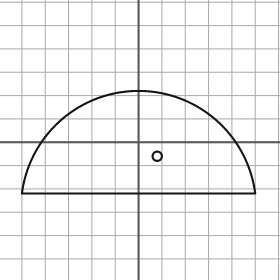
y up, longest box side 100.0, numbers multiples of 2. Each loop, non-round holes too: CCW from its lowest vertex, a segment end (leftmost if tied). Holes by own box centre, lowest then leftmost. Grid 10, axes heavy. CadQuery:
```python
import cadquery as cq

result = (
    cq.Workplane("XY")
    .moveTo(-50.0, -22.0)
    .lineTo(50.0, -22.0)
    .threePointArc((0.0, 22.0), (-50.0, -22.0))
    .close()
    .moveTo(8.0, -6.0)
    .circle(2.0)
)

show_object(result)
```